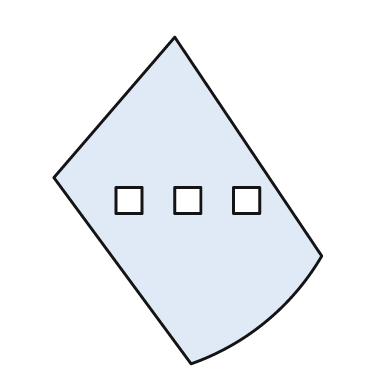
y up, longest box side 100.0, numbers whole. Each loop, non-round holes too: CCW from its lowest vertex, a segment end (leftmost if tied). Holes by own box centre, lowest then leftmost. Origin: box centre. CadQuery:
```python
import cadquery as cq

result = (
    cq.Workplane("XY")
    .moveTo(1.0, -50.0)
    .threePointArc((24.0, -37.0), (41.0, -17.0))
    .lineTo(-4.0, 50.0)
    .lineTo(-41.0, 7.0)
    .close()
    .moveTo(-22.0, -4.0)
    .lineTo(-14.0, -4.0)
    .lineTo(-14.0, 4.0)
    .lineTo(-22.0, 4.0)
    .close()
    .moveTo(-4.0, -4.0)
    .lineTo(4.0, -4.0)
    .lineTo(4.0, 4.0)
    .lineTo(-4.0, 4.0)
    .close()
    .moveTo(14.0, -4.0)
    .lineTo(22.0, -4.0)
    .lineTo(22.0, 4.0)
    .lineTo(14.0, 4.0)
    .close()
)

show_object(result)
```